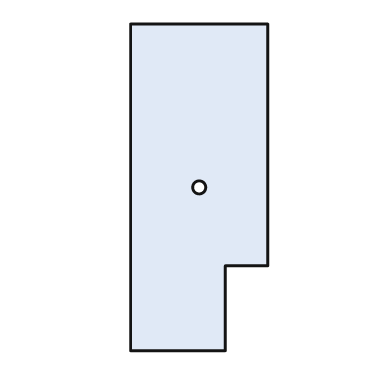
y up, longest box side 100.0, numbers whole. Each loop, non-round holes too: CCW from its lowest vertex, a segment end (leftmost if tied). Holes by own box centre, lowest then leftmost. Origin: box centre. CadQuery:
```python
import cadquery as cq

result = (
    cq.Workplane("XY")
    .moveTo(-21.0, -50.0)
    .lineTo(8.0, -50.0)
    .lineTo(8.0, -24.0)
    .lineTo(21.0, -24.0)
    .lineTo(21.0, 50.0)
    .lineTo(-21.0, 50.0)
    .close()
    .moveTo(0.0, 0.0)
    .circle(2.0)
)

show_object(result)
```